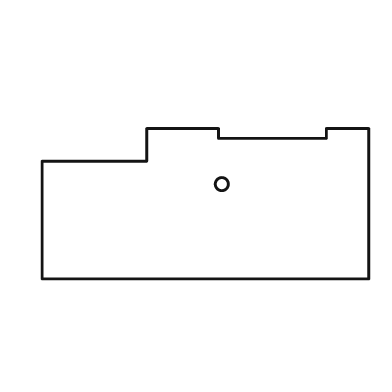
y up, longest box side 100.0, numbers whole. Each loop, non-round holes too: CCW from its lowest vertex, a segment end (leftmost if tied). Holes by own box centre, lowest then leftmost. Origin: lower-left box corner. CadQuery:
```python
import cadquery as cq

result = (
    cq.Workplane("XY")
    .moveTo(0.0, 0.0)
    .lineTo(100.0, 0.0)
    .lineTo(100.0, 46.0)
    .lineTo(87.0, 46.0)
    .lineTo(87.0, 43.0)
    .lineTo(54.0, 43.0)
    .lineTo(54.0, 46.0)
    .lineTo(32.0, 46.0)
    .lineTo(32.0, 36.0)
    .lineTo(0.0, 36.0)
    .close()
    .moveTo(55.0, 29.0)
    .circle(2.0)
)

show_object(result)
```